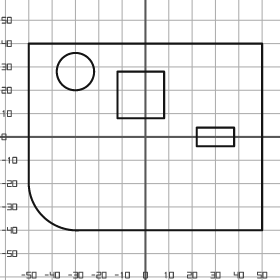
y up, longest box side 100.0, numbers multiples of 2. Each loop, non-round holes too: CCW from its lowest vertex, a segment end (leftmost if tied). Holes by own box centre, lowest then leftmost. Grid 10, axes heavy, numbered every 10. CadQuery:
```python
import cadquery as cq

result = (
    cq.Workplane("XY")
    .moveTo(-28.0, -40.0)
    .lineTo(50.0, -40.0)
    .lineTo(50.0, 40.0)
    .lineTo(-50.0, 40.0)
    .lineTo(-50.0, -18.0)
    .threePointArc((-44.0, -34.0), (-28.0, -40.0))
    .close()
    .moveTo(22.0, -4.0)
    .lineTo(38.0, -4.0)
    .lineTo(38.0, 4.0)
    .lineTo(22.0, 4.0)
    .close()
    .moveTo(-12.0, 8.0)
    .lineTo(8.0, 8.0)
    .lineTo(8.0, 28.0)
    .lineTo(-12.0, 28.0)
    .close()
    .moveTo(-30.0, 28.0)
    .circle(8.0)
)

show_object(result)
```